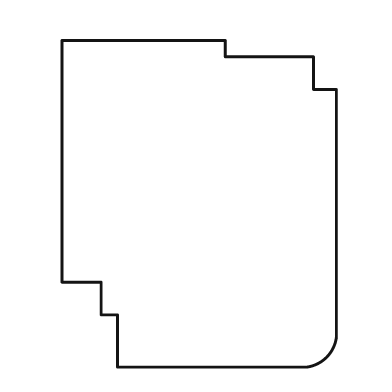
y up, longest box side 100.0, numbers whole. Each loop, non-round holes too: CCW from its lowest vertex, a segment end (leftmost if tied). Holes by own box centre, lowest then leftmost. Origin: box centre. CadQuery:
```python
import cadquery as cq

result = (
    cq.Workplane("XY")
    .moveTo(-25.0, -50.0)
    .lineTo(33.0, -50.0)
    .threePointArc((39.0, -47.0), (42.0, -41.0))
    .lineTo(42.0, 35.0)
    .lineTo(35.0, 35.0)
    .lineTo(35.0, 45.0)
    .lineTo(8.0, 45.0)
    .lineTo(8.0, 50.0)
    .lineTo(-42.0, 50.0)
    .lineTo(-42.0, -24.0)
    .lineTo(-30.0, -24.0)
    .lineTo(-30.0, -34.0)
    .lineTo(-25.0, -34.0)
    .close()
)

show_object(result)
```